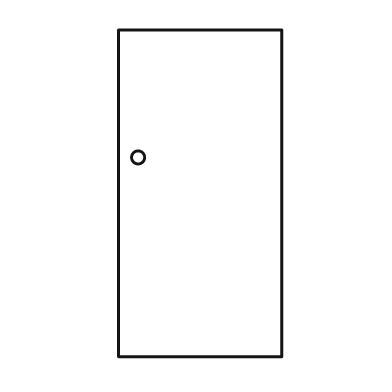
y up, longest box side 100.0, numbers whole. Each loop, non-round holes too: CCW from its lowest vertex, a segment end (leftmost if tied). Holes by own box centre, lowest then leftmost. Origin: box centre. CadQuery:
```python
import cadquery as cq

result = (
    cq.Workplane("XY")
    .moveTo(-25.0, -50.0)
    .lineTo(25.0, -50.0)
    .lineTo(25.0, 50.0)
    .lineTo(-25.0, 50.0)
    .close()
    .moveTo(-19.0, 11.0)
    .circle(2.0)
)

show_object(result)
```